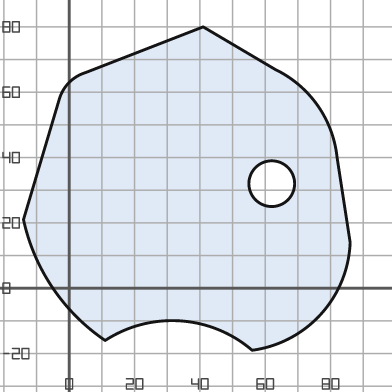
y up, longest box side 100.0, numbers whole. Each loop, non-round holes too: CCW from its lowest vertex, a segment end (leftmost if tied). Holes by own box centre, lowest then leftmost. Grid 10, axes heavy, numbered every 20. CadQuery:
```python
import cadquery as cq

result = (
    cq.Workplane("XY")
    .moveTo(56.0, -19.0)
    .threePointArc((77.0, -8.0), (86.0, 14.0))
    .lineTo(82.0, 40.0)
    .threePointArc((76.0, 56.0), (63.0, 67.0))
    .lineTo(41.0, 80.0)
    .lineTo(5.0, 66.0)
    .threePointArc((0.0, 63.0), (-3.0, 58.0))
    .lineTo(-14.0, 21.0)
    .threePointArc((-5.0, 0.0), (11.0, -16.0))
    .threePointArc((34.0, -10.0), (56.0, -19.0))
    .close()
    .moveTo(62.0, 32.0)
    .circle(7.0)
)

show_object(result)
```